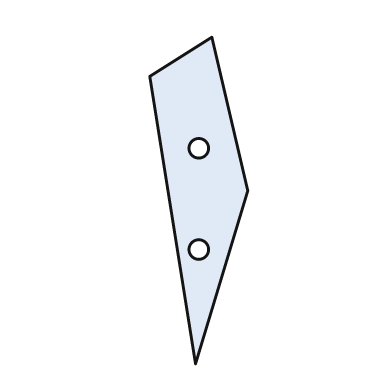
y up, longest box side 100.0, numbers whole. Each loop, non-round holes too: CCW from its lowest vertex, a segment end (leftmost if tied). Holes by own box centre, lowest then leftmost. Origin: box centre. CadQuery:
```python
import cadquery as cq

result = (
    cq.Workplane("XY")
    .moveTo(-1.0, -50.0)
    .lineTo(15.0, 3.0)
    .lineTo(4.0, 50.0)
    .lineTo(-15.0, 38.0)
    .close()
    .moveTo(0.0, -15.0)
    .circle(3.0)
    .moveTo(0.0, 16.0)
    .circle(3.0)
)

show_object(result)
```